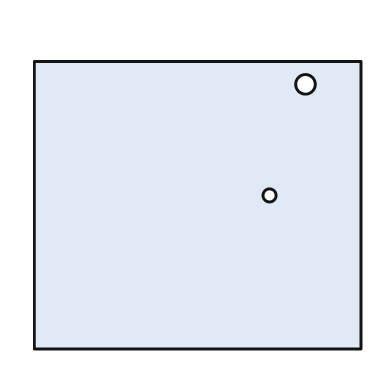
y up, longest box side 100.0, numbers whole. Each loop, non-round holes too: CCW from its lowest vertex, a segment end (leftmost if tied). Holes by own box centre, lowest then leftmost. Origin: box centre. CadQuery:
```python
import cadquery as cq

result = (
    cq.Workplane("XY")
    .moveTo(-50.0, -44.0)
    .lineTo(50.0, -44.0)
    .lineTo(50.0, 44.0)
    .lineTo(-50.0, 44.0)
    .close()
    .moveTo(22.0, 3.0)
    .circle(2.0)
    .moveTo(33.0, 37.0)
    .circle(3.0)
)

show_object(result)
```